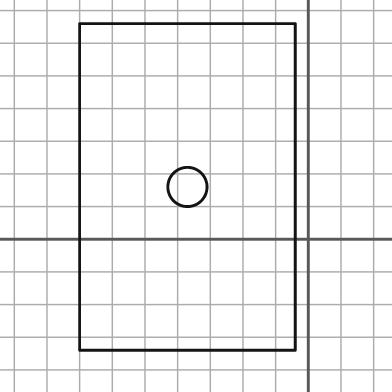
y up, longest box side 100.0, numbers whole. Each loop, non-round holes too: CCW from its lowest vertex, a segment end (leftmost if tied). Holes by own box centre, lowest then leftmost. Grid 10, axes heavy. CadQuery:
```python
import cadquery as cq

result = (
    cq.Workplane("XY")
    .moveTo(-70.0, -34.0)
    .lineTo(-4.0, -34.0)
    .lineTo(-4.0, 66.0)
    .lineTo(-70.0, 66.0)
    .close()
    .moveTo(-37.0, 16.0)
    .circle(6.0)
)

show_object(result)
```